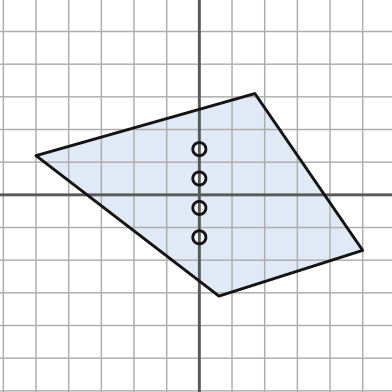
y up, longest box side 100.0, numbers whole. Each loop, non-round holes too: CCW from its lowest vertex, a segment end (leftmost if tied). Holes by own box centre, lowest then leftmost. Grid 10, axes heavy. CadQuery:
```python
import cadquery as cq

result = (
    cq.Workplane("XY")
    .moveTo(6.0, -31.0)
    .lineTo(50.0, -17.0)
    .lineTo(17.0, 31.0)
    .lineTo(-50.0, 12.0)
    .close()
    .moveTo(0.0, -13.0)
    .circle(2.0)
    .moveTo(0.0, -4.0)
    .circle(2.0)
    .moveTo(0.0, 5.0)
    .circle(2.0)
    .moveTo(0.0, 14.0)
    .circle(2.0)
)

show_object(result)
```